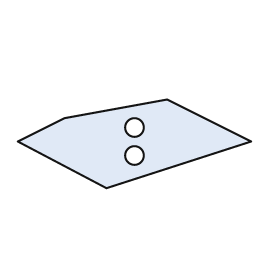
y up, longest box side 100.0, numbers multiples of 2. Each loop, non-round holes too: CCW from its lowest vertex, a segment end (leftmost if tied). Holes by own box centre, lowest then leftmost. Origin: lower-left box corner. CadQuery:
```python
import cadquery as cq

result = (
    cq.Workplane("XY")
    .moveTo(38.0, 0.0)
    .lineTo(100.0, 20.0)
    .lineTo(64.0, 38.0)
    .lineTo(20.0, 30.0)
    .lineTo(0.0, 20.0)
    .close()
    .moveTo(50.0, 14.0)
    .circle(4.0)
    .moveTo(50.0, 26.0)
    .circle(4.0)
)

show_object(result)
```